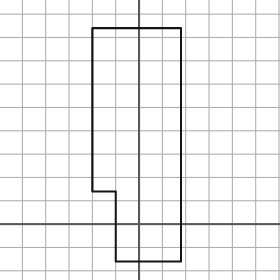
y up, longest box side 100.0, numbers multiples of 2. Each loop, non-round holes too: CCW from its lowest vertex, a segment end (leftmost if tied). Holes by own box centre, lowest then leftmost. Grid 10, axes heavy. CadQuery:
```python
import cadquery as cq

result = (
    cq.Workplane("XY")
    .moveTo(-10.0, -16.0)
    .lineTo(18.0, -16.0)
    .lineTo(18.0, 84.0)
    .lineTo(-20.0, 84.0)
    .lineTo(-20.0, 14.0)
    .lineTo(-10.0, 14.0)
    .close()
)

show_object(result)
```